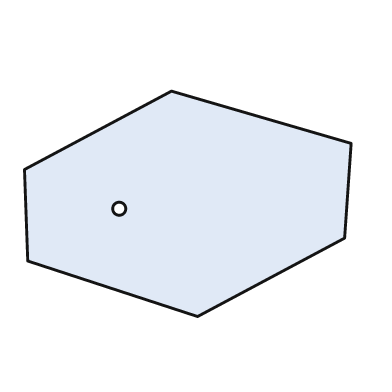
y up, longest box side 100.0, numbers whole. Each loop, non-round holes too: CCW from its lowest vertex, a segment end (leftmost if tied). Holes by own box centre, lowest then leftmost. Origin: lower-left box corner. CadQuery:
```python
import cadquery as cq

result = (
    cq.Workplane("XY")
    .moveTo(53.0, 0.0)
    .lineTo(98.0, 24.0)
    .lineTo(100.0, 53.0)
    .lineTo(45.0, 69.0)
    .lineTo(0.0, 45.0)
    .lineTo(1.0, 17.0)
    .close()
    .moveTo(29.0, 33.0)
    .circle(2.0)
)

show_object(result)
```